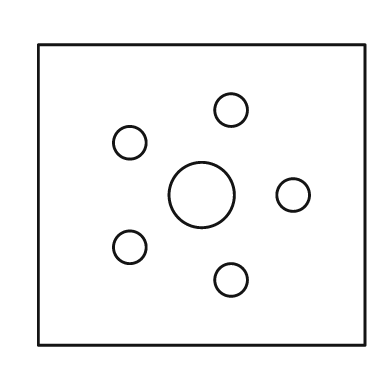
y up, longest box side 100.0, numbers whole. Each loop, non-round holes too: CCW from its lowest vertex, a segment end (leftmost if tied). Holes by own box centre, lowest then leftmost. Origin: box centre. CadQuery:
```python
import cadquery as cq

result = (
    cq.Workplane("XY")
    .moveTo(-50.0, -46.0)
    .lineTo(50.0, -46.0)
    .lineTo(50.0, 46.0)
    .lineTo(-50.0, 46.0)
    .close()
    .moveTo(9.0, -26.0)
    .circle(5.0)
    .moveTo(-22.0, -16.0)
    .circle(5.0)
    .moveTo(0.0, 0.0)
    .circle(10.0)
    .moveTo(28.0, 0.0)
    .circle(5.0)
    .moveTo(-22.0, 16.0)
    .circle(5.0)
    .moveTo(9.0, 26.0)
    .circle(5.0)
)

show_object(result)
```